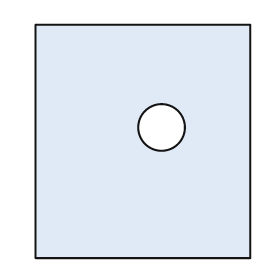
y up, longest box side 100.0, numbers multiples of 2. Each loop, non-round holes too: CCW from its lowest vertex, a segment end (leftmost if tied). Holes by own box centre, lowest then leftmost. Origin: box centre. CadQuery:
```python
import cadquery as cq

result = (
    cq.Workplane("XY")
    .moveTo(-46.0, -50.0)
    .lineTo(46.0, -50.0)
    .lineTo(46.0, 50.0)
    .lineTo(-46.0, 50.0)
    .close()
    .moveTo(8.0, 6.0)
    .circle(10.0)
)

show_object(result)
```